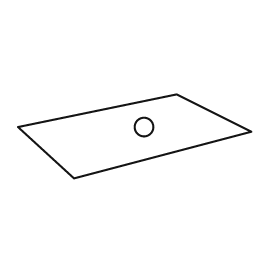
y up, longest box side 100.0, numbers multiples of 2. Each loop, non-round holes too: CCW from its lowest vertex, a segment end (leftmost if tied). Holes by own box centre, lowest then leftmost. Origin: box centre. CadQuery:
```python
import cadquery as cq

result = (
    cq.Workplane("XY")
    .moveTo(-26.0, -18.0)
    .lineTo(50.0, 2.0)
    .lineTo(18.0, 18.0)
    .lineTo(-50.0, 4.0)
    .close()
    .moveTo(4.0, 4.0)
    .circle(4.0)
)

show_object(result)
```